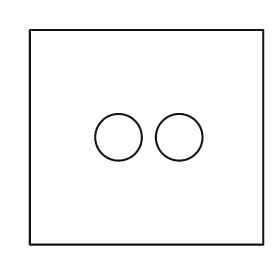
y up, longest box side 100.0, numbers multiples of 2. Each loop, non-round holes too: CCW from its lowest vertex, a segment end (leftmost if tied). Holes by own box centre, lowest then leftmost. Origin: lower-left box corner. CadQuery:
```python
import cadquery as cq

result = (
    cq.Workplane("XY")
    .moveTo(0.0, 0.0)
    .lineTo(100.0, 0.0)
    .lineTo(100.0, 92.0)
    .lineTo(0.0, 92.0)
    .close()
    .moveTo(38.0, 46.0)
    .circle(10.0)
    .moveTo(64.0, 46.0)
    .circle(10.0)
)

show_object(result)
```